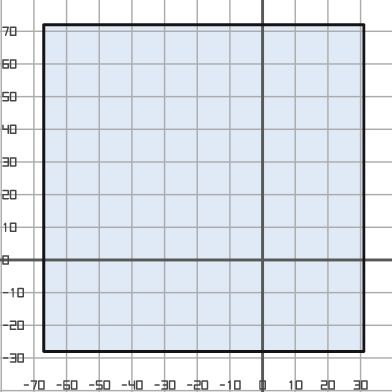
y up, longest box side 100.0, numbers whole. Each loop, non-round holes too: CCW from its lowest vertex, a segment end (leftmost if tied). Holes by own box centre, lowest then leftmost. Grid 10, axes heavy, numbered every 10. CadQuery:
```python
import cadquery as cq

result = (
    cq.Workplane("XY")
    .moveTo(-67.0, -28.0)
    .lineTo(31.0, -28.0)
    .lineTo(31.0, 72.0)
    .lineTo(-67.0, 72.0)
    .close()
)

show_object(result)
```